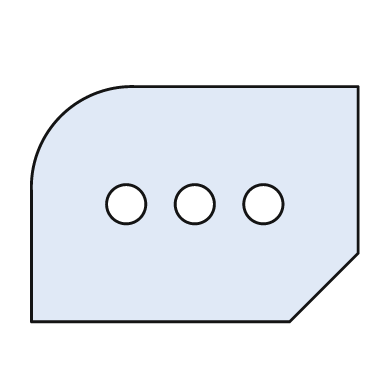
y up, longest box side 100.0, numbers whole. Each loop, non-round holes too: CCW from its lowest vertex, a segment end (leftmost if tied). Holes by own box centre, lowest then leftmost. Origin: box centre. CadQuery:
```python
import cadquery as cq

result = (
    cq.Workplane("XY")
    .moveTo(-50.0, -36.0)
    .lineTo(29.0, -36.0)
    .lineTo(50.0, -15.0)
    .lineTo(50.0, 36.0)
    .lineTo(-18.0, 36.0)
    .threePointArc((-41.0, 27.0), (-50.0, 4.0))
    .close()
    .moveTo(-21.0, 0.0)
    .circle(6.0)
    .moveTo(0.0, 0.0)
    .circle(6.0)
    .moveTo(21.0, 0.0)
    .circle(6.0)
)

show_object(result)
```